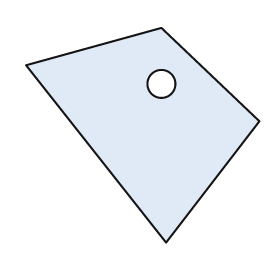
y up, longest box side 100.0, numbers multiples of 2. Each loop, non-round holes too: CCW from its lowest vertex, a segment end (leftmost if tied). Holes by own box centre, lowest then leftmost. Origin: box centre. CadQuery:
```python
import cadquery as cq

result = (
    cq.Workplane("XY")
    .moveTo(10.0, -46.0)
    .lineTo(50.0, 6.0)
    .lineTo(8.0, 46.0)
    .lineTo(-50.0, 30.0)
    .close()
    .moveTo(8.0, 22.0)
    .circle(6.0)
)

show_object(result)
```